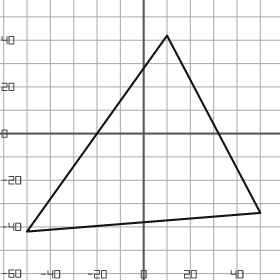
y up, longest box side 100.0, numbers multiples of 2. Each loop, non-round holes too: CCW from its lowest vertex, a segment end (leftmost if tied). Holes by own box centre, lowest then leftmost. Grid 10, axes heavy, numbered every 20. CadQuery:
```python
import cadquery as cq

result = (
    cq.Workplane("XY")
    .moveTo(-50.0, -42.0)
    .lineTo(50.0, -34.0)
    .lineTo(10.0, 42.0)
    .close()
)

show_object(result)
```